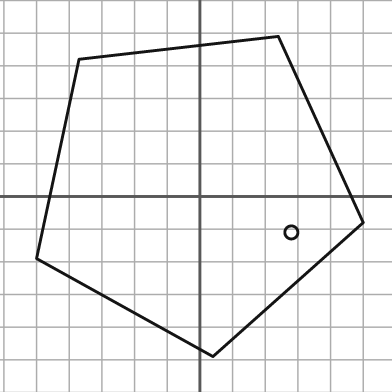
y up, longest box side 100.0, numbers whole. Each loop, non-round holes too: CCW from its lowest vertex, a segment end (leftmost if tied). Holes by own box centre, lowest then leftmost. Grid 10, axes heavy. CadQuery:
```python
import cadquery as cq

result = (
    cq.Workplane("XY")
    .moveTo(4.0, -49.0)
    .lineTo(50.0, -8.0)
    .lineTo(24.0, 49.0)
    .lineTo(-37.0, 42.0)
    .lineTo(-50.0, -19.0)
    .close()
    .moveTo(28.0, -11.0)
    .circle(2.0)
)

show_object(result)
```